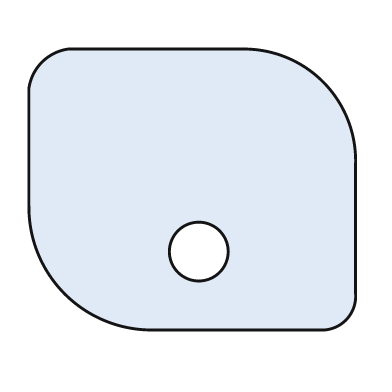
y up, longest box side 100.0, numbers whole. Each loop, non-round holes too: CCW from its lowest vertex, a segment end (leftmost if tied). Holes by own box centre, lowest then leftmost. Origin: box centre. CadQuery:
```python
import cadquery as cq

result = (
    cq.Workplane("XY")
    .moveTo(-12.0, -43.0)
    .lineTo(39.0, -43.0)
    .threePointArc((47.0, -40.0), (50.0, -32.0))
    .lineTo(50.0, 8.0)
    .threePointArc((40.0, 33.0), (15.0, 43.0))
    .lineTo(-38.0, 43.0)
    .threePointArc((-46.0, 39.0), (-50.0, 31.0))
    .lineTo(-50.0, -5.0)
    .threePointArc((-39.0, -32.0), (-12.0, -43.0))
    .close()
    .moveTo(2.0, -19.0)
    .circle(9.0)
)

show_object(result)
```